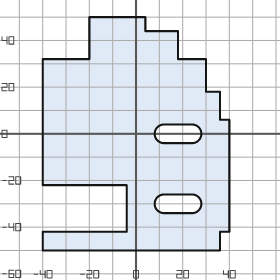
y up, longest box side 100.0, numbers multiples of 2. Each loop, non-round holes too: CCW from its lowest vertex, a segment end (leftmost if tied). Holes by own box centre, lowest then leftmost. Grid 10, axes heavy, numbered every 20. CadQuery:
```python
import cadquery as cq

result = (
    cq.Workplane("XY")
    .moveTo(-40.0, -50.0)
    .lineTo(36.0, -50.0)
    .lineTo(36.0, -42.0)
    .lineTo(40.0, -42.0)
    .lineTo(40.0, 6.0)
    .lineTo(36.0, 6.0)
    .lineTo(36.0, 18.0)
    .lineTo(30.0, 18.0)
    .lineTo(30.0, 32.0)
    .lineTo(18.0, 32.0)
    .lineTo(18.0, 44.0)
    .lineTo(4.0, 44.0)
    .lineTo(4.0, 50.0)
    .lineTo(-20.0, 50.0)
    .lineTo(-20.0, 32.0)
    .lineTo(-40.0, 32.0)
    .lineTo(-40.0, -22.0)
    .lineTo(-4.0, -22.0)
    .lineTo(-4.0, -42.0)
    .lineTo(-40.0, -42.0)
    .close()
    .moveTo(12.0, -34.0)
    .lineTo(24.0, -34.0)
    .threePointArc((28.0, -30.0), (24.0, -26.0))
    .lineTo(12.0, -26.0)
    .threePointArc((8.0, -30.0), (12.0, -34.0))
    .close()
    .moveTo(12.0, -4.0)
    .lineTo(24.0, -4.0)
    .threePointArc((28.0, 0.0), (24.0, 4.0))
    .lineTo(12.0, 4.0)
    .threePointArc((8.0, 0.0), (12.0, -4.0))
    .close()
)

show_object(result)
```